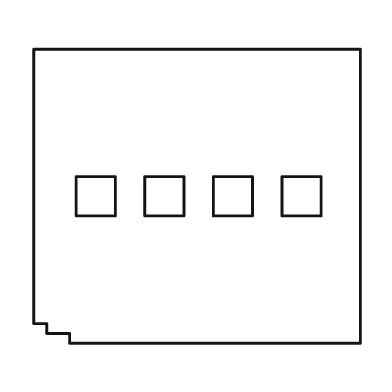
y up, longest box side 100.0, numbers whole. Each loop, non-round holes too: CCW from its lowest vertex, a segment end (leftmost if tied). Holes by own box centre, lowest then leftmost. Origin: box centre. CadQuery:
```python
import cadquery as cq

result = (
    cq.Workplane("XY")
    .moveTo(-39.0, -45.0)
    .lineTo(50.0, -45.0)
    .lineTo(50.0, 45.0)
    .lineTo(-50.0, 45.0)
    .lineTo(-50.0, -39.0)
    .lineTo(-46.0, -39.0)
    .lineTo(-46.0, -42.0)
    .lineTo(-39.0, -42.0)
    .close()
    .moveTo(-37.0, -6.0)
    .lineTo(-25.0, -6.0)
    .lineTo(-25.0, 6.0)
    .lineTo(-37.0, 6.0)
    .close()
    .moveTo(-16.0, -6.0)
    .lineTo(-4.0, -6.0)
    .lineTo(-4.0, 6.0)
    .lineTo(-16.0, 6.0)
    .close()
    .moveTo(5.0, -6.0)
    .lineTo(17.0, -6.0)
    .lineTo(17.0, 6.0)
    .lineTo(5.0, 6.0)
    .close()
    .moveTo(26.0, -6.0)
    .lineTo(38.0, -6.0)
    .lineTo(38.0, 6.0)
    .lineTo(26.0, 6.0)
    .close()
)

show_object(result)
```